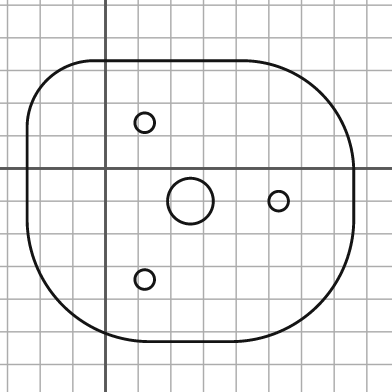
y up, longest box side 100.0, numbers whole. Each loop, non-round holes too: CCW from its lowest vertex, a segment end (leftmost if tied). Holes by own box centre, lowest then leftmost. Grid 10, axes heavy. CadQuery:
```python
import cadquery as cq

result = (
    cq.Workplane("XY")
    .moveTo(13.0, -53.0)
    .lineTo(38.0, -53.0)
    .threePointArc((65.0, -42.0), (76.0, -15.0))
    .lineTo(76.0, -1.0)
    .threePointArc((66.0, 23.0), (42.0, 33.0))
    .lineTo(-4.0, 33.0)
    .threePointArc((-18.0, 27.0), (-24.0, 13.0))
    .lineTo(-24.0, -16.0)
    .threePointArc((-13.0, -42.0), (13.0, -53.0))
    .close()
    .moveTo(12.0, -34.0)
    .circle(3.0)
    .moveTo(26.0, -10.0)
    .circle(7.0)
    .moveTo(53.0, -10.0)
    .circle(3.0)
    .moveTo(12.0, 14.0)
    .circle(3.0)
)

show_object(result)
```